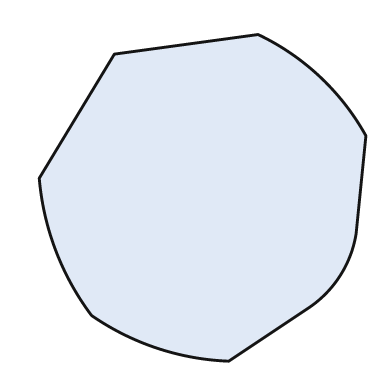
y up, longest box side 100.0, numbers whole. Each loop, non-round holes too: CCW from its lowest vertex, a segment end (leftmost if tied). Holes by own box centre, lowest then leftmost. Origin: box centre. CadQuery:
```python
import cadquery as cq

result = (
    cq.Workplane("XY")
    .moveTo(8.0, -50.0)
    .lineTo(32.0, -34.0)
    .threePointArc((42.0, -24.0), (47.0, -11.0))
    .lineTo(50.0, 19.0)
    .threePointArc((36.0, 37.0), (17.0, 50.0))
    .lineTo(-27.0, 44.0)
    .lineTo(-50.0, 6.0)
    .threePointArc((-45.0, -16.0), (-34.0, -36.0))
    .threePointArc((-14.0, -46.0), (8.0, -50.0))
    .close()
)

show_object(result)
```